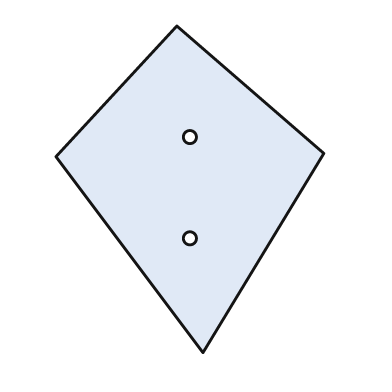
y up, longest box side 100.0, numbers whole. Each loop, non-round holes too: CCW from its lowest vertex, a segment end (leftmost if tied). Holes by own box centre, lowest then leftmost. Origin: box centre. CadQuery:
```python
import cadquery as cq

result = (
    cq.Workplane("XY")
    .moveTo(4.0, -50.0)
    .lineTo(41.0, 11.0)
    .lineTo(-4.0, 50.0)
    .lineTo(-41.0, 10.0)
    .close()
    .moveTo(0.0, -15.0)
    .circle(2.0)
    .moveTo(0.0, 16.0)
    .circle(2.0)
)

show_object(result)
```